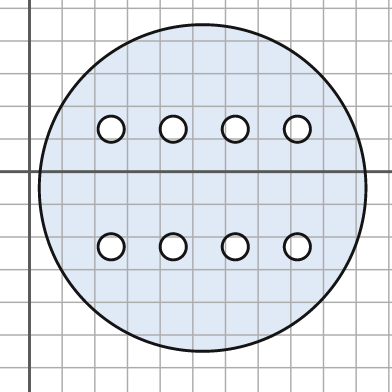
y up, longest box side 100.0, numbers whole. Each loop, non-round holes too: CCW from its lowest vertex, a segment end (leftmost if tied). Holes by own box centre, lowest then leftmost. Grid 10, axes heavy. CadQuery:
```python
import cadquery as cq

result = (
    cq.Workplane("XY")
    .moveTo(53.0, -5.0)
    .circle(50.0)
    .moveTo(25.0, -23.0)
    .circle(4.0)
    .moveTo(44.0, -23.0)
    .circle(4.0)
    .moveTo(63.0, -23.0)
    .circle(4.0)
    .moveTo(82.0, -23.0)
    .circle(4.0)
    .moveTo(25.0, 13.0)
    .circle(4.0)
    .moveTo(44.0, 13.0)
    .circle(4.0)
    .moveTo(63.0, 13.0)
    .circle(4.0)
    .moveTo(82.0, 13.0)
    .circle(4.0)
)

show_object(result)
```